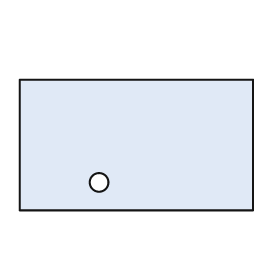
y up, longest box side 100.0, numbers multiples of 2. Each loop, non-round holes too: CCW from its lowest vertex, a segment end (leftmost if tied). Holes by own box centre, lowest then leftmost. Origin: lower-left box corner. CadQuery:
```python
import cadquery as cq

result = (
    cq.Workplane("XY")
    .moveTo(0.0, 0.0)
    .lineTo(100.0, 0.0)
    .lineTo(100.0, 56.0)
    .lineTo(0.0, 56.0)
    .close()
    .moveTo(34.0, 12.0)
    .circle(4.0)
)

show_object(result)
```